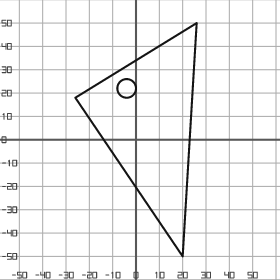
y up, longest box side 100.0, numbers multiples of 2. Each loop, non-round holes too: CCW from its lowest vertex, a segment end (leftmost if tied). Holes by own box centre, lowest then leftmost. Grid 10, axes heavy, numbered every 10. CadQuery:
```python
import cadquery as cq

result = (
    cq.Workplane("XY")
    .moveTo(20.0, -50.0)
    .lineTo(26.0, 50.0)
    .lineTo(-26.0, 18.0)
    .close()
    .moveTo(-4.0, 22.0)
    .circle(4.0)
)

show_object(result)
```